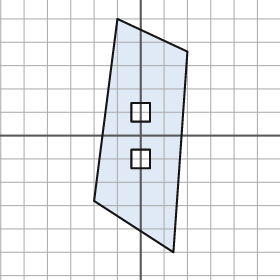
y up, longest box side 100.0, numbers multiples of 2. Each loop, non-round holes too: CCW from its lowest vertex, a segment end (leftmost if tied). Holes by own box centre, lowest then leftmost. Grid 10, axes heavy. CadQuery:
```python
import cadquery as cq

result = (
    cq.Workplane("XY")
    .moveTo(14.0, -50.0)
    .lineTo(20.0, 36.0)
    .lineTo(-10.0, 50.0)
    .lineTo(-20.0, -28.0)
    .close()
    .moveTo(-4.0, -14.0)
    .lineTo(4.0, -14.0)
    .lineTo(4.0, -6.0)
    .lineTo(-4.0, -6.0)
    .close()
    .moveTo(-4.0, 6.0)
    .lineTo(4.0, 6.0)
    .lineTo(4.0, 14.0)
    .lineTo(-4.0, 14.0)
    .close()
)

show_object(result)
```